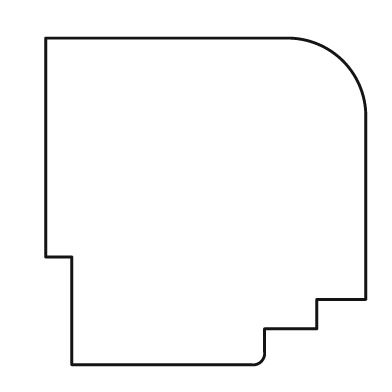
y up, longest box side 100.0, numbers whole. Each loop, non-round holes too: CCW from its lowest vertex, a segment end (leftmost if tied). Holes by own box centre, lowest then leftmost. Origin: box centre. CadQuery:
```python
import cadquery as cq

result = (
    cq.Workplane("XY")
    .moveTo(-41.0, -50.0)
    .lineTo(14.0, -50.0)
    .threePointArc((17.0, -49.0), (18.0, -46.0))
    .lineTo(18.0, -39.0)
    .lineTo(34.0, -39.0)
    .lineTo(34.0, -30.0)
    .lineTo(49.0, -30.0)
    .lineTo(49.0, 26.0)
    .threePointArc((42.0, 43.0), (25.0, 50.0))
    .lineTo(-49.0, 50.0)
    .lineTo(-49.0, -17.0)
    .lineTo(-41.0, -17.0)
    .close()
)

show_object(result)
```